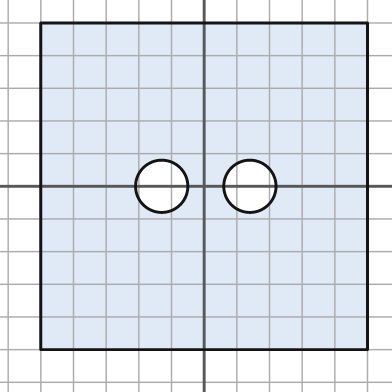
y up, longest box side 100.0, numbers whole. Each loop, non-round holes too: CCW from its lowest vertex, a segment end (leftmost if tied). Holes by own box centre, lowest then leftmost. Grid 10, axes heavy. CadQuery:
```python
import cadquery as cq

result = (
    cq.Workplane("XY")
    .moveTo(-50.0, -50.0)
    .lineTo(50.0, -50.0)
    .lineTo(50.0, 50.0)
    .lineTo(-50.0, 50.0)
    .close()
    .moveTo(-13.0, 0.0)
    .circle(8.0)
    .moveTo(14.0, 0.0)
    .circle(8.0)
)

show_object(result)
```